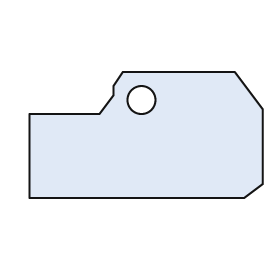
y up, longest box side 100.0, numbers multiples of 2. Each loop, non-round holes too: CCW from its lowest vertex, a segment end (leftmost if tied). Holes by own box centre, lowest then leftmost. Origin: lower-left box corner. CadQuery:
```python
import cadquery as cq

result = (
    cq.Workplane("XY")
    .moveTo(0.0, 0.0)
    .lineTo(92.0, 0.0)
    .lineTo(100.0, 6.0)
    .lineTo(100.0, 38.0)
    .lineTo(88.0, 54.0)
    .lineTo(40.0, 54.0)
    .lineTo(36.0, 48.0)
    .lineTo(36.0, 44.0)
    .lineTo(30.0, 36.0)
    .lineTo(0.0, 36.0)
    .close()
    .moveTo(48.0, 42.0)
    .circle(6.0)
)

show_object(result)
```